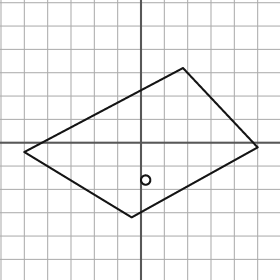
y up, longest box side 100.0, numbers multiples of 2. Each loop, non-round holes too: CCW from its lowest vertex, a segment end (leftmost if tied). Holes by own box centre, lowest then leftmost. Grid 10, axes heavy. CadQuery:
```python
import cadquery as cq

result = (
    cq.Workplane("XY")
    .moveTo(-4.0, -32.0)
    .lineTo(50.0, -2.0)
    .lineTo(18.0, 32.0)
    .lineTo(-50.0, -4.0)
    .close()
    .moveTo(2.0, -16.0)
    .circle(2.0)
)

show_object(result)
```